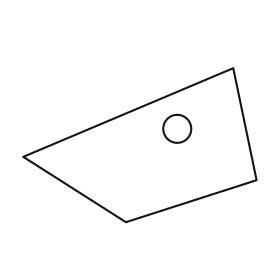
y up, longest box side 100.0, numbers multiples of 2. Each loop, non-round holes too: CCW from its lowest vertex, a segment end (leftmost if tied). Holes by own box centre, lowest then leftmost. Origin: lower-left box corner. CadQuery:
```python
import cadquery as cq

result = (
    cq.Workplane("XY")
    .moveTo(44.0, 0.0)
    .lineTo(100.0, 18.0)
    .lineTo(90.0, 66.0)
    .lineTo(0.0, 28.0)
    .close()
    .moveTo(66.0, 40.0)
    .circle(6.0)
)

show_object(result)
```